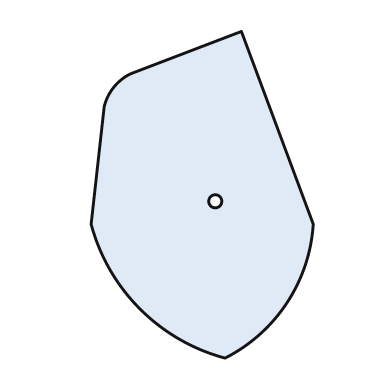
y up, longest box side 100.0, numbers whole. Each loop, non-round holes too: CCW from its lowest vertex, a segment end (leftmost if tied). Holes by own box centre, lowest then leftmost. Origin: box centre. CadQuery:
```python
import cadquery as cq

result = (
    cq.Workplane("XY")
    .moveTo(7.0, -50.0)
    .threePointArc((26.0, -33.0), (34.0, -9.0))
    .lineTo(12.0, 50.0)
    .lineTo(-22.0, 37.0)
    .threePointArc((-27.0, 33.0), (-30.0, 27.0))
    .lineTo(-34.0, -9.0)
    .threePointArc((-19.0, -35.0), (7.0, -50.0))
    .close()
    .moveTo(4.0, -2.0)
    .circle(2.0)
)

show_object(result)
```